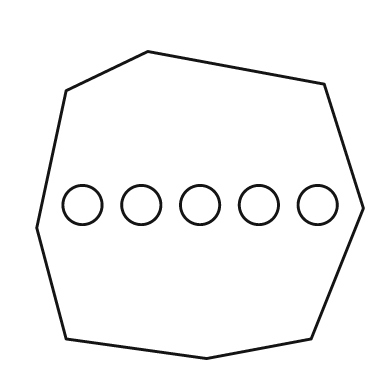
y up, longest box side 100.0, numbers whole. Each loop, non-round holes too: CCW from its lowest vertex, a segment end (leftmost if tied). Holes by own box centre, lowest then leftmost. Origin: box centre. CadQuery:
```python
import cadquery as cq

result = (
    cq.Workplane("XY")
    .moveTo(2.0, -47.0)
    .lineTo(34.0, -41.0)
    .lineTo(50.0, -1.0)
    .lineTo(38.0, 37.0)
    .lineTo(-16.0, 47.0)
    .lineTo(-41.0, 35.0)
    .lineTo(-50.0, -7.0)
    .lineTo(-41.0, -41.0)
    .close()
    .moveTo(-36.0, 0.0)
    .circle(6.0)
    .moveTo(-18.0, 0.0)
    .circle(6.0)
    .moveTo(0.0, 0.0)
    .circle(6.0)
    .moveTo(18.0, 0.0)
    .circle(6.0)
    .moveTo(36.0, 0.0)
    .circle(6.0)
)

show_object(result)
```